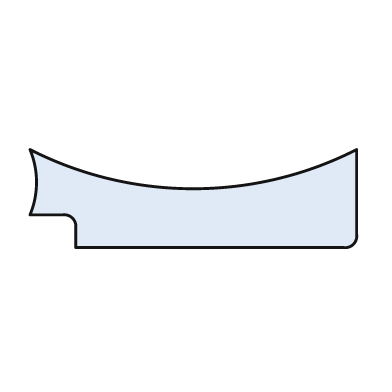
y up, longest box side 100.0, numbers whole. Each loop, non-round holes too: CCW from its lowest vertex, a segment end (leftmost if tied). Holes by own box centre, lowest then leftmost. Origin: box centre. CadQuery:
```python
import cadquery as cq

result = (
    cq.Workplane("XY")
    .moveTo(-36.0, -15.0)
    .lineTo(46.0, -15.0)
    .threePointArc((49.0, -14.0), (50.0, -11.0))
    .lineTo(50.0, 15.0)
    .threePointArc((0.0, 3.0), (-50.0, 15.0))
    .threePointArc((-48.0, 5.0), (-50.0, -5.0))
    .lineTo(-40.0, -5.0)
    .threePointArc((-37.0, -6.0), (-36.0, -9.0))
    .close()
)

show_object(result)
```